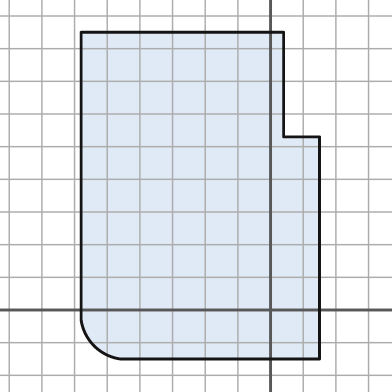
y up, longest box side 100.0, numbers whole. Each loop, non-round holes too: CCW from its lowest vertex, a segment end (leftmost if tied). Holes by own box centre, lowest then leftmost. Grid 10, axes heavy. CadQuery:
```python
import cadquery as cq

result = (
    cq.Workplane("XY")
    .moveTo(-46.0, -15.0)
    .lineTo(15.0, -15.0)
    .lineTo(15.0, 53.0)
    .lineTo(4.0, 53.0)
    .lineTo(4.0, 85.0)
    .lineTo(-58.0, 85.0)
    .lineTo(-58.0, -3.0)
    .threePointArc((-54.0, -11.0), (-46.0, -15.0))
    .close()
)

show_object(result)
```